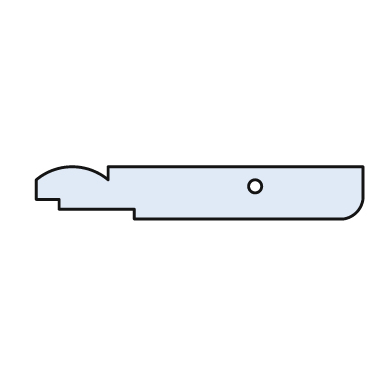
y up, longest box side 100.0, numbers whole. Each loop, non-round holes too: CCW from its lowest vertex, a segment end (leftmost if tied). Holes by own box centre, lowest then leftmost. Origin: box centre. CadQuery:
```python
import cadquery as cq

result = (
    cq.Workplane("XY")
    .moveTo(-20.0, -8.0)
    .lineTo(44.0, -8.0)
    .threePointArc((48.0, -6.0), (50.0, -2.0))
    .lineTo(50.0, 8.0)
    .lineTo(-28.0, 8.0)
    .lineTo(-28.0, 4.0)
    .threePointArc((-39.0, 8.0), (-50.0, 4.0))
    .lineTo(-50.0, -2.0)
    .lineTo(-43.0, -2.0)
    .lineTo(-43.0, -5.0)
    .lineTo(-20.0, -5.0)
    .close()
    .moveTo(17.0, 2.0)
    .circle(2.0)
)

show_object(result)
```